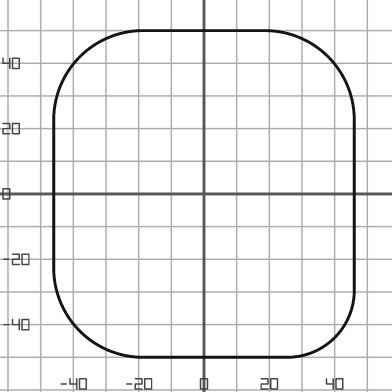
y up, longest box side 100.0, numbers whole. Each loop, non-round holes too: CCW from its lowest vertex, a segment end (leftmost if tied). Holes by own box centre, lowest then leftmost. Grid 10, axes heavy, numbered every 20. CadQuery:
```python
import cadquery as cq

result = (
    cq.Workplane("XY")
    .moveTo(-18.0, -50.0)
    .lineTo(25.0, -50.0)
    .threePointArc((40.0, -44.0), (46.0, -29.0))
    .lineTo(46.0, 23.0)
    .threePointArc((38.0, 42.0), (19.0, 50.0))
    .lineTo(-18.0, 50.0)
    .threePointArc((-38.0, 42.0), (-46.0, 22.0))
    .lineTo(-46.0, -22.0)
    .threePointArc((-38.0, -42.0), (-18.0, -50.0))
    .close()
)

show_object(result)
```